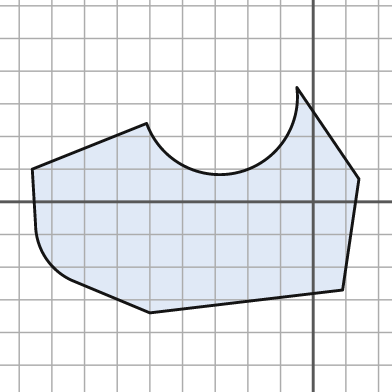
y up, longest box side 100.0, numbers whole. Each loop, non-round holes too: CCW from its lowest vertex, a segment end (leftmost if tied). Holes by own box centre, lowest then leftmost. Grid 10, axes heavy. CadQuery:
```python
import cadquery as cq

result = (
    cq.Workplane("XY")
    .moveTo(-50.0, -34.0)
    .lineTo(9.0, -27.0)
    .lineTo(14.0, 7.0)
    .lineTo(-5.0, 35.0)
    .threePointArc((-23.0, 9.0), (-51.0, 24.0))
    .lineTo(-86.0, 10.0)
    .lineTo(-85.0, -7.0)
    .threePointArc((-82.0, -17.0), (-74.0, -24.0))
    .close()
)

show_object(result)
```